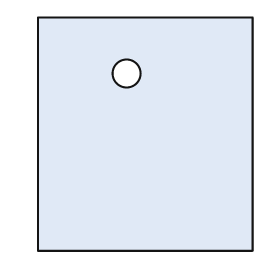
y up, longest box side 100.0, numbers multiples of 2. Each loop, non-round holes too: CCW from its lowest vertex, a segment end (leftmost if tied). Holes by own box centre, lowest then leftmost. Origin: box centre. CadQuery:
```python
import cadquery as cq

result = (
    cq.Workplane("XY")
    .moveTo(-46.0, -50.0)
    .lineTo(46.0, -50.0)
    .lineTo(46.0, 50.0)
    .lineTo(-46.0, 50.0)
    .close()
    .moveTo(-8.0, 26.0)
    .circle(6.0)
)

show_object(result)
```